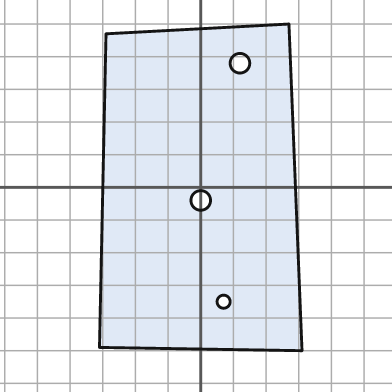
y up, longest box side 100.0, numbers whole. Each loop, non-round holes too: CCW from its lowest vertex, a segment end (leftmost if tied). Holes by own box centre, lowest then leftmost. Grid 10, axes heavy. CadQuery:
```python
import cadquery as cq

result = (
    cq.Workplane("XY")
    .moveTo(31.0, -50.0)
    .lineTo(27.0, 50.0)
    .lineTo(-29.0, 47.0)
    .lineTo(-31.0, -49.0)
    .close()
    .moveTo(7.0, -35.0)
    .circle(2.0)
    .moveTo(0.0, -4.0)
    .circle(3.0)
    .moveTo(12.0, 38.0)
    .circle(3.0)
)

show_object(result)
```